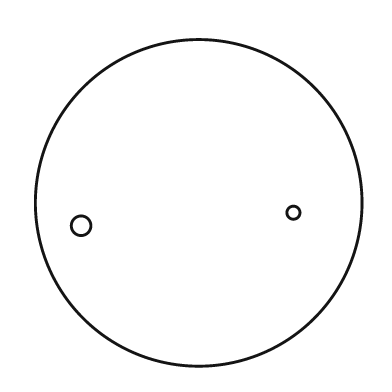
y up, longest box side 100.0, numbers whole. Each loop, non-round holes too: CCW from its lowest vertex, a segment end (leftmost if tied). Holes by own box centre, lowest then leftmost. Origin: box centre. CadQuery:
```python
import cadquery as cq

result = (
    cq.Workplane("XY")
    .moveTo(0.0, 0.0)
    .circle(50.0)
    .moveTo(-36.0, -7.0)
    .circle(3.0)
    .moveTo(29.0, -3.0)
    .circle(2.0)
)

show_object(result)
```